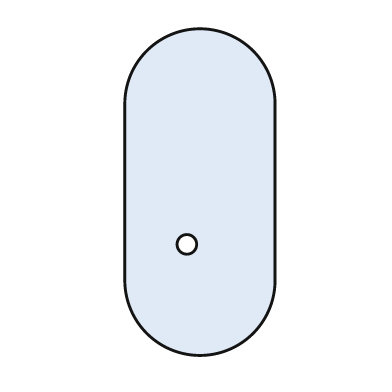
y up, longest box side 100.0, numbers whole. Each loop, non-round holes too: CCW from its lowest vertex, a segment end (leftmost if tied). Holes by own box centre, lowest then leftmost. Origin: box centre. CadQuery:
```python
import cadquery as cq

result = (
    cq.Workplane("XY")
    .moveTo(-23.0, -27.0)
    .threePointArc((0.0, -50.0), (23.0, -27.0))
    .lineTo(23.0, 27.0)
    .threePointArc((0.0, 50.0), (-23.0, 27.0))
    .close()
    .moveTo(-4.0, -16.0)
    .circle(3.0)
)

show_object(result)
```